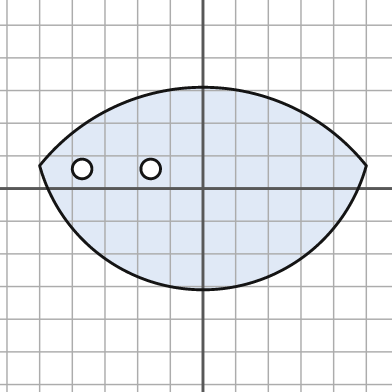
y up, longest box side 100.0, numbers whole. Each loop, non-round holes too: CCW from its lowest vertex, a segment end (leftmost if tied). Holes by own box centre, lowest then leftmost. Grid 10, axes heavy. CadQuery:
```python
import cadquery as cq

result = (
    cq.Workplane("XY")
    .moveTo(-50.0, 7.0)
    .threePointArc((0.0, -31.0), (50.0, 7.0))
    .threePointArc((0.0, 31.0), (-50.0, 7.0))
    .close()
    .moveTo(-37.0, 6.0)
    .circle(3.0)
    .moveTo(-16.0, 6.0)
    .circle(3.0)
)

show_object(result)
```